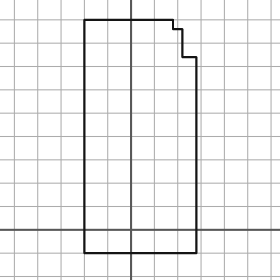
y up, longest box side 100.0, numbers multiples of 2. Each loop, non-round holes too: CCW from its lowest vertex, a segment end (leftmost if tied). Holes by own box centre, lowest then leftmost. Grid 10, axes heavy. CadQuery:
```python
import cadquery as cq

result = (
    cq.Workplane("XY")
    .moveTo(-20.0, -10.0)
    .lineTo(28.0, -10.0)
    .lineTo(28.0, 74.0)
    .lineTo(22.0, 74.0)
    .lineTo(22.0, 86.0)
    .lineTo(18.0, 86.0)
    .lineTo(18.0, 90.0)
    .lineTo(-20.0, 90.0)
    .close()
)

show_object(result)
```